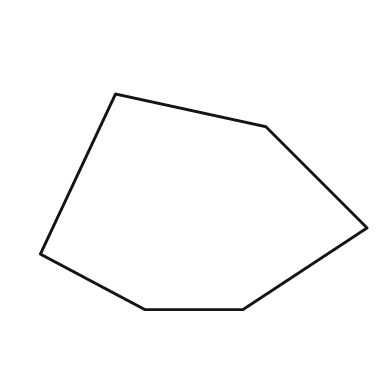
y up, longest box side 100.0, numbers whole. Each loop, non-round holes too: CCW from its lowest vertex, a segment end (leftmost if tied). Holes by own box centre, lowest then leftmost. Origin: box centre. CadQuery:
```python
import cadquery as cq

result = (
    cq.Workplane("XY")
    .moveTo(-18.0, -33.0)
    .lineTo(12.0, -33.0)
    .lineTo(50.0, -8.0)
    .lineTo(19.0, 23.0)
    .lineTo(-27.0, 33.0)
    .lineTo(-50.0, -16.0)
    .close()
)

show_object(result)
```